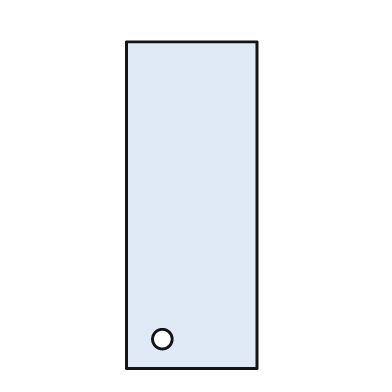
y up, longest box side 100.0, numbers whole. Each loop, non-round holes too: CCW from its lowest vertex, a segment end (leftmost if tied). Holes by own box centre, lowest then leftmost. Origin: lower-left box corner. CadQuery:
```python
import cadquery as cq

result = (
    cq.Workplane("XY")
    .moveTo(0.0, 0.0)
    .lineTo(40.0, 0.0)
    .lineTo(40.0, 100.0)
    .lineTo(0.0, 100.0)
    .close()
    .moveTo(11.0, 9.0)
    .circle(3.0)
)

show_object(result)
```